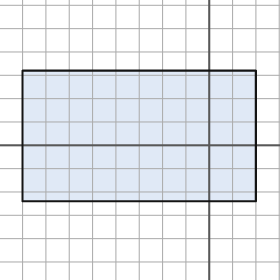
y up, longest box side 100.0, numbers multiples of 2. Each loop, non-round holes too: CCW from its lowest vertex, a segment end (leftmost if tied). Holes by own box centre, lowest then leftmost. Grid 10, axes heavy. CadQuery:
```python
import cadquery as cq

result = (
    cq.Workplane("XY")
    .moveTo(-80.0, -24.0)
    .lineTo(20.0, -24.0)
    .lineTo(20.0, 32.0)
    .lineTo(-80.0, 32.0)
    .close()
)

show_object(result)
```